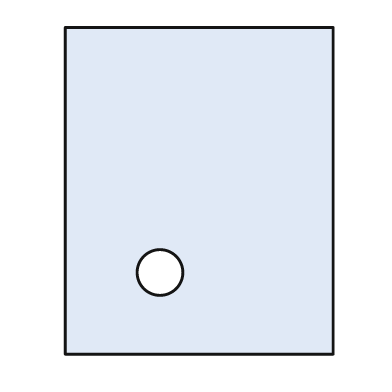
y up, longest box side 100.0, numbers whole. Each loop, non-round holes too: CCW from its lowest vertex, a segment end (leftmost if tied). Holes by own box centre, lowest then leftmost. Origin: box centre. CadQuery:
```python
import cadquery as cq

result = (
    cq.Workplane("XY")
    .moveTo(-41.0, -50.0)
    .lineTo(41.0, -50.0)
    .lineTo(41.0, 50.0)
    .lineTo(-41.0, 50.0)
    .close()
    .moveTo(-12.0, -25.0)
    .circle(7.0)
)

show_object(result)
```